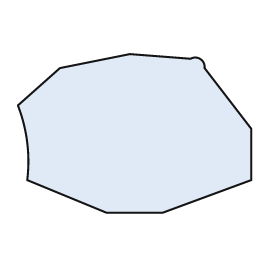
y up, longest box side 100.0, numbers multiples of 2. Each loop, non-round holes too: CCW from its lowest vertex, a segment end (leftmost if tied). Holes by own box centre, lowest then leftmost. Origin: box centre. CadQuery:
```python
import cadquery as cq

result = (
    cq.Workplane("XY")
    .moveTo(-12.0, -34.0)
    .lineTo(12.0, -34.0)
    .lineTo(50.0, -20.0)
    .lineTo(50.0, 2.0)
    .lineTo(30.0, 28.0)
    .threePointArc((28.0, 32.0), (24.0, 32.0))
    .lineTo(-2.0, 34.0)
    .lineTo(-32.0, 28.0)
    .lineTo(-50.0, 12.0)
    .threePointArc((-46.0, -4.0), (-46.0, -20.0))
    .close()
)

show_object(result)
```